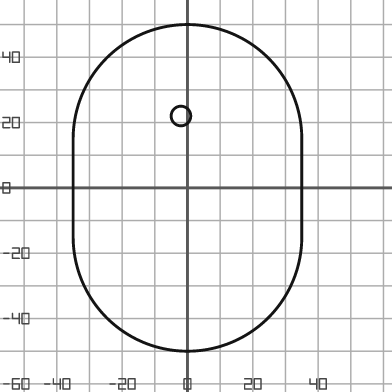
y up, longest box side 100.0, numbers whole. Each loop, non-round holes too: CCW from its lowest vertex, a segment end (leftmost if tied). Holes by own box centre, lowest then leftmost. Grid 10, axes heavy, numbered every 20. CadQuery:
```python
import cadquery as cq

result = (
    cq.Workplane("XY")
    .moveTo(-35.0, -15.0)
    .threePointArc((0.0, -50.0), (35.0, -15.0))
    .lineTo(35.0, 15.0)
    .threePointArc((0.0, 50.0), (-35.0, 15.0))
    .close()
    .moveTo(-2.0, 22.0)
    .circle(3.0)
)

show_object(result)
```